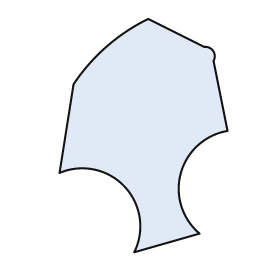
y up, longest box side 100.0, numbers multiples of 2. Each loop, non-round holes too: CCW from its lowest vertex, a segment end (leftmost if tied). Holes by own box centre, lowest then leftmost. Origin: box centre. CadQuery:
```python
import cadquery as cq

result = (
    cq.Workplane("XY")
    .moveTo(-4.0, -50.0)
    .lineTo(24.0, -42.0)
    .threePointArc((16.0, -16.0), (36.0, 2.0))
    .lineTo(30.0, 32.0)
    .threePointArc((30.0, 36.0), (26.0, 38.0))
    .lineTo(2.0, 50.0)
    .threePointArc((-16.0, 38.0), (-30.0, 22.0))
    .lineTo(-36.0, -16.0)
    .threePointArc((-8.0, -22.0), (-4.0, -50.0))
    .close()
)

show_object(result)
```